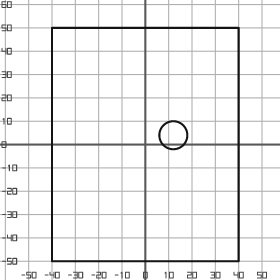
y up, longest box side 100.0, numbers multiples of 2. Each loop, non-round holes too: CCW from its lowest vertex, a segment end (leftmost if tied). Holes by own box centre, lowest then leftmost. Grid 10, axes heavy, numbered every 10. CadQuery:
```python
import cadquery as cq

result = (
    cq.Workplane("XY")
    .moveTo(-40.0, -50.0)
    .lineTo(40.0, -50.0)
    .lineTo(40.0, 50.0)
    .lineTo(-40.0, 50.0)
    .close()
    .moveTo(12.0, 4.0)
    .circle(6.0)
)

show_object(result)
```